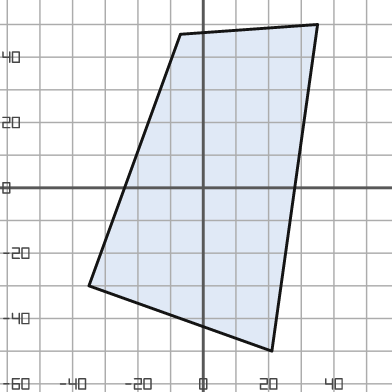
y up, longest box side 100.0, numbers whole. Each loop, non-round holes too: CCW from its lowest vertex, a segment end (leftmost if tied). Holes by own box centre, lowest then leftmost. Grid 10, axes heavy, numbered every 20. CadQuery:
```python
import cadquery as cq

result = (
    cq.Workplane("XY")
    .moveTo(21.0, -50.0)
    .lineTo(35.0, 50.0)
    .lineTo(-7.0, 47.0)
    .lineTo(-35.0, -30.0)
    .close()
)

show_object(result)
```